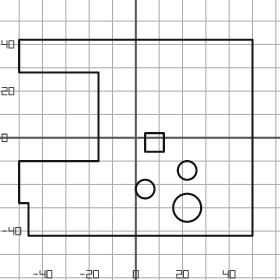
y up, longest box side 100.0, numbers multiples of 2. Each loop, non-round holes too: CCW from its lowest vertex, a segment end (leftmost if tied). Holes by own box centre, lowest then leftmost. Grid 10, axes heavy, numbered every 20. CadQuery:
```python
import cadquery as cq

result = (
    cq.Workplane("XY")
    .moveTo(-46.0, -42.0)
    .lineTo(50.0, -42.0)
    .lineTo(50.0, 42.0)
    .lineTo(-50.0, 42.0)
    .lineTo(-50.0, 28.0)
    .lineTo(-16.0, 28.0)
    .lineTo(-16.0, -10.0)
    .lineTo(-50.0, -10.0)
    .lineTo(-50.0, -28.0)
    .lineTo(-46.0, -28.0)
    .close()
    .moveTo(22.0, -30.0)
    .circle(6.0)
    .moveTo(4.0, -22.0)
    .circle(4.0)
    .moveTo(22.0, -14.0)
    .circle(4.0)
    .moveTo(4.0, -6.0)
    .lineTo(12.0, -6.0)
    .lineTo(12.0, 2.0)
    .lineTo(4.0, 2.0)
    .close()
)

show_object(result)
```